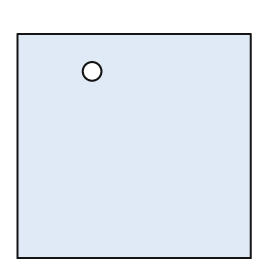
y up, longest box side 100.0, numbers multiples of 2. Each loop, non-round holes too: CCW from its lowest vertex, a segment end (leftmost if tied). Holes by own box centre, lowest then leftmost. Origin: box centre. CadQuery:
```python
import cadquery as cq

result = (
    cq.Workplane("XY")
    .moveTo(-50.0, -48.0)
    .lineTo(50.0, -48.0)
    .lineTo(50.0, 48.0)
    .lineTo(-50.0, 48.0)
    .close()
    .moveTo(-18.0, 32.0)
    .circle(4.0)
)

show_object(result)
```